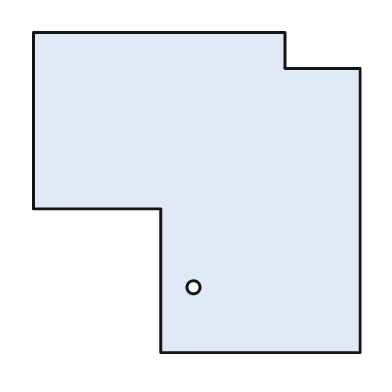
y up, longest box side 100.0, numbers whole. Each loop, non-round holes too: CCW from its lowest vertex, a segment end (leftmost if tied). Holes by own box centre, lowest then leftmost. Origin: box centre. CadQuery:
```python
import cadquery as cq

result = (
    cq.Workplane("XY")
    .moveTo(-11.0, -49.0)
    .lineTo(50.0, -49.0)
    .lineTo(50.0, 38.0)
    .lineTo(27.0, 38.0)
    .lineTo(27.0, 49.0)
    .lineTo(-50.0, 49.0)
    .lineTo(-50.0, -5.0)
    .lineTo(-11.0, -5.0)
    .close()
    .moveTo(-1.0, -29.0)
    .circle(2.0)
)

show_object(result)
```